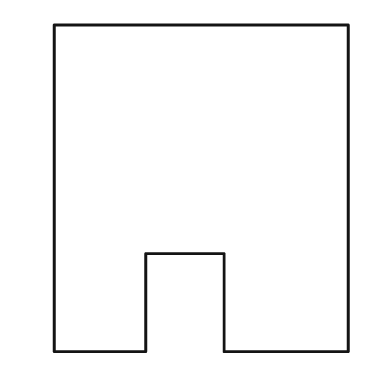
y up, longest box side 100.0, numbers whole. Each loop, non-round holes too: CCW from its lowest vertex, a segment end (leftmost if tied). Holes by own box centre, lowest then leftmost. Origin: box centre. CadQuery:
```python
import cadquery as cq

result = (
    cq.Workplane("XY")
    .moveTo(-45.0, -50.0)
    .lineTo(-17.0, -50.0)
    .lineTo(-17.0, -20.0)
    .lineTo(7.0, -20.0)
    .lineTo(7.0, -50.0)
    .lineTo(45.0, -50.0)
    .lineTo(45.0, 50.0)
    .lineTo(-45.0, 50.0)
    .close()
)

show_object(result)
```